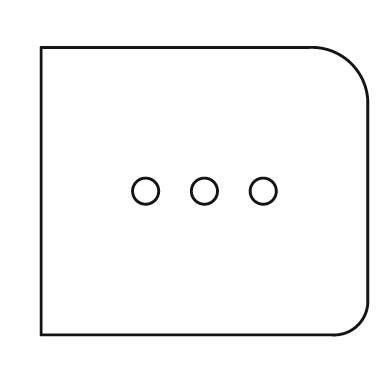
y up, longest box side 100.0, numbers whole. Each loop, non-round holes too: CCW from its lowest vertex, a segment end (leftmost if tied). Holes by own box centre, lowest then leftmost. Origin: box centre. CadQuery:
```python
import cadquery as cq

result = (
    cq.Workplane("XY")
    .moveTo(-50.0, -44.0)
    .lineTo(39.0, -44.0)
    .threePointArc((47.0, -41.0), (50.0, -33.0))
    .lineTo(50.0, 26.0)
    .threePointArc((45.0, 39.0), (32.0, 44.0))
    .lineTo(-50.0, 44.0)
    .close()
    .moveTo(-18.0, 0.0)
    .circle(4.0)
    .moveTo(0.0, 0.0)
    .circle(4.0)
    .moveTo(18.0, 0.0)
    .circle(4.0)
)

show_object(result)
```